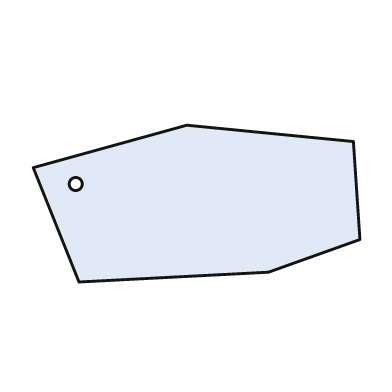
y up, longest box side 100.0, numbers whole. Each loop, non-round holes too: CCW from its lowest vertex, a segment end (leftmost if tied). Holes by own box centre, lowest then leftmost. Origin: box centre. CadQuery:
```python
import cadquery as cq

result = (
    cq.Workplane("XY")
    .moveTo(-36.0, -24.0)
    .lineTo(22.0, -21.0)
    .lineTo(50.0, -11.0)
    .lineTo(48.0, 19.0)
    .lineTo(-3.0, 24.0)
    .lineTo(-50.0, 11.0)
    .close()
    .moveTo(-37.0, 6.0)
    .circle(2.0)
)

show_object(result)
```